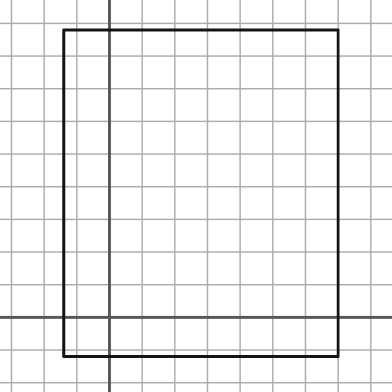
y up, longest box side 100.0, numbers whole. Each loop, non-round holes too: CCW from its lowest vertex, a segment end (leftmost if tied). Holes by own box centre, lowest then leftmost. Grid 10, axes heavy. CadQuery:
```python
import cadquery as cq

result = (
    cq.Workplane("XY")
    .moveTo(-14.0, -12.0)
    .lineTo(70.0, -12.0)
    .lineTo(70.0, 88.0)
    .lineTo(-14.0, 88.0)
    .close()
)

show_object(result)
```